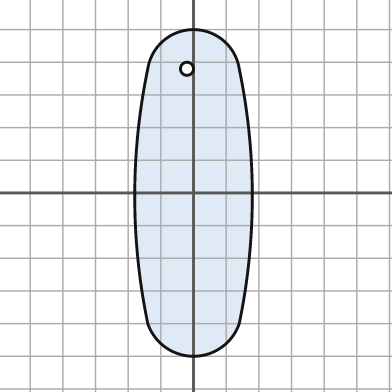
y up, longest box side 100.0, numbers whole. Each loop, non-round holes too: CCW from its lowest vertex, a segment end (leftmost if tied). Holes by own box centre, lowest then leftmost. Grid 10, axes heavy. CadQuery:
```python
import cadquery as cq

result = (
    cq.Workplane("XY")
    .moveTo(-14.0, -40.0)
    .threePointArc((0.0, -50.0), (14.0, -40.0))
    .threePointArc((18.0, -1.0), (14.0, 38.0))
    .threePointArc((0.0, 50.0), (-14.0, 38.0))
    .threePointArc((-18.0, -1.0), (-14.0, -40.0))
    .close()
    .moveTo(-2.0, 38.0)
    .circle(2.0)
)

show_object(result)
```